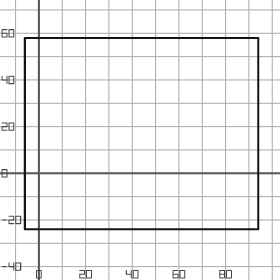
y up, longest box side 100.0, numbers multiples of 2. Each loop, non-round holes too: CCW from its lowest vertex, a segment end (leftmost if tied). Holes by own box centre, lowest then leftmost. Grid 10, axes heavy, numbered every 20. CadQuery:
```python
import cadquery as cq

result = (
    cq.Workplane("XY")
    .moveTo(-6.0, -24.0)
    .lineTo(94.0, -24.0)
    .lineTo(94.0, 58.0)
    .lineTo(-6.0, 58.0)
    .close()
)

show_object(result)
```